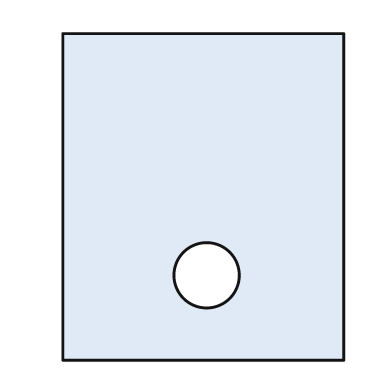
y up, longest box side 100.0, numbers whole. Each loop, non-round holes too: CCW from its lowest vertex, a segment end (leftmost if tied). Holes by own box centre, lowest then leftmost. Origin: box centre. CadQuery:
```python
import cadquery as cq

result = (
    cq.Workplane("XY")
    .moveTo(-43.0, -50.0)
    .lineTo(43.0, -50.0)
    .lineTo(43.0, 50.0)
    .lineTo(-43.0, 50.0)
    .close()
    .moveTo(1.0, -24.0)
    .circle(10.0)
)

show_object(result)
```